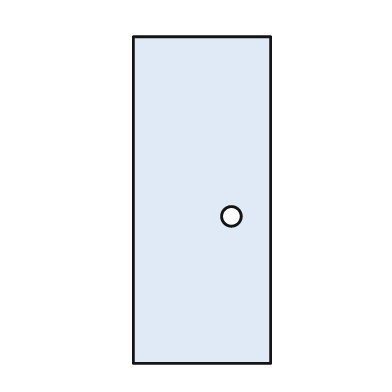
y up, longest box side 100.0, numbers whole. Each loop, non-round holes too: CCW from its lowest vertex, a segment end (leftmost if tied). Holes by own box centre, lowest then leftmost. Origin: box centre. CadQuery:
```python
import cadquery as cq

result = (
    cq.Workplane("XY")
    .moveTo(-21.0, -50.0)
    .lineTo(21.0, -50.0)
    .lineTo(21.0, 50.0)
    .lineTo(-21.0, 50.0)
    .close()
    .moveTo(9.0, -5.0)
    .circle(3.0)
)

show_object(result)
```